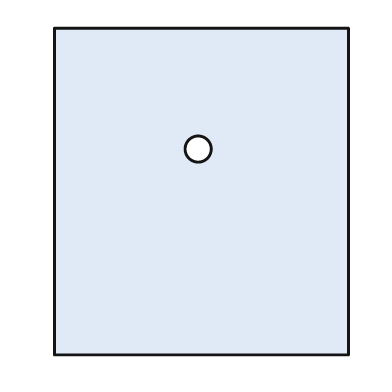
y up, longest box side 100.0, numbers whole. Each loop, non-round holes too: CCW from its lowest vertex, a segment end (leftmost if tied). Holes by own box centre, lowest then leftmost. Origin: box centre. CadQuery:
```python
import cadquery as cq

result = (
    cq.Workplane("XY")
    .moveTo(-45.0, -50.0)
    .lineTo(45.0, -50.0)
    .lineTo(45.0, 50.0)
    .lineTo(-45.0, 50.0)
    .close()
    .moveTo(-1.0, 13.0)
    .circle(4.0)
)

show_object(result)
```